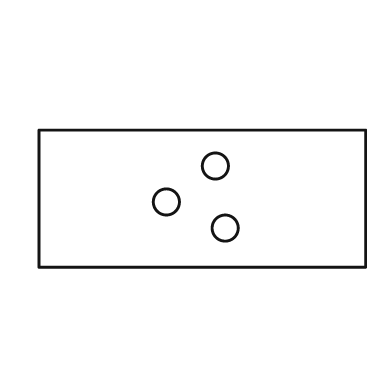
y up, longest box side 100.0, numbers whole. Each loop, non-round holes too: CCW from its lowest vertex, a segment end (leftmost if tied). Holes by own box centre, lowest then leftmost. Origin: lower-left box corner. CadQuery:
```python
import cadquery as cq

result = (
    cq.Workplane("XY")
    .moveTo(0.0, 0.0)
    .lineTo(100.0, 0.0)
    .lineTo(100.0, 42.0)
    .lineTo(0.0, 42.0)
    .close()
    .moveTo(57.0, 12.0)
    .circle(4.0)
    .moveTo(39.0, 20.0)
    .circle(4.0)
    .moveTo(54.0, 31.0)
    .circle(4.0)
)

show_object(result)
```